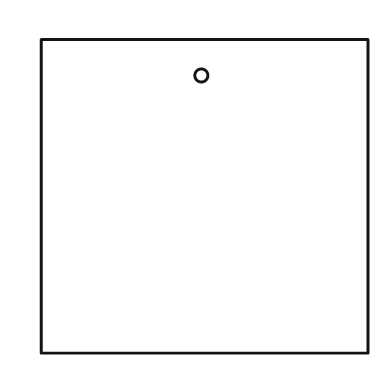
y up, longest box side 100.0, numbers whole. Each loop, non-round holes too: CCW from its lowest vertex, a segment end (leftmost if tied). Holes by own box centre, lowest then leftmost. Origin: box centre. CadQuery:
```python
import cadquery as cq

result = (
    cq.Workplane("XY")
    .moveTo(-50.0, -48.0)
    .lineTo(50.0, -48.0)
    .lineTo(50.0, 48.0)
    .lineTo(-50.0, 48.0)
    .close()
    .moveTo(-1.0, 37.0)
    .circle(2.0)
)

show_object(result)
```